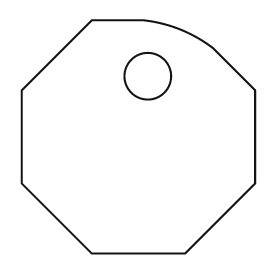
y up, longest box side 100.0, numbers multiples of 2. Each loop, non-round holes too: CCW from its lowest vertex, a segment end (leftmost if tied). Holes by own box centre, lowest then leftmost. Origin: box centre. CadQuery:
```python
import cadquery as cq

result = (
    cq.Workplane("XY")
    .moveTo(-20.0, -50.0)
    .lineTo(20.0, -50.0)
    .lineTo(50.0, -20.0)
    .lineTo(50.0, 20.0)
    .lineTo(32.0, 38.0)
    .threePointArc((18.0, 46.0), (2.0, 50.0))
    .lineTo(-20.0, 50.0)
    .lineTo(-50.0, 20.0)
    .lineTo(-50.0, -20.0)
    .close()
    .moveTo(4.0, 26.0)
    .circle(10.0)
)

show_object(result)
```